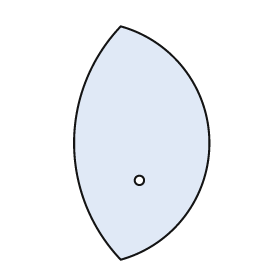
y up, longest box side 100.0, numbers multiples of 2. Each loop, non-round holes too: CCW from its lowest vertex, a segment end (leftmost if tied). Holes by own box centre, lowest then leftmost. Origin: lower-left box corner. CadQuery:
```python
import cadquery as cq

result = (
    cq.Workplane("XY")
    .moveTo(20.0, 0.0)
    .threePointArc((58.0, 50.0), (20.0, 100.0))
    .threePointArc((0.0, 50.0), (20.0, 0.0))
    .close()
    .moveTo(28.0, 34.0)
    .circle(2.0)
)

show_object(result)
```